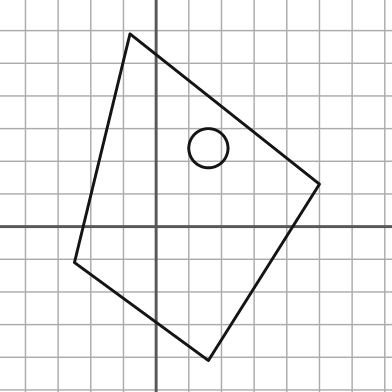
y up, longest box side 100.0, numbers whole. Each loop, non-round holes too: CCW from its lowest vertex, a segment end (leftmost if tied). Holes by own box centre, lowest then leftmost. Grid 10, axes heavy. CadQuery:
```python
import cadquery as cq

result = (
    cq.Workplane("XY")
    .moveTo(16.0, -41.0)
    .lineTo(50.0, 13.0)
    .lineTo(-8.0, 59.0)
    .lineTo(-25.0, -11.0)
    .close()
    .moveTo(16.0, 24.0)
    .circle(6.0)
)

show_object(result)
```